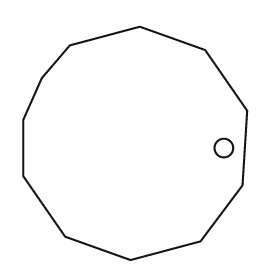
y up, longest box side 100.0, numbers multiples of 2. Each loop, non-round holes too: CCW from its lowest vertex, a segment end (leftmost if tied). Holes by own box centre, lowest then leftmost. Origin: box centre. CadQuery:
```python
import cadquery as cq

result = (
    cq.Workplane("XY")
    .moveTo(-2.0, -50.0)
    .lineTo(28.0, -42.0)
    .lineTo(46.0, -18.0)
    .lineTo(48.0, 14.0)
    .lineTo(30.0, 40.0)
    .lineTo(2.0, 50.0)
    .lineTo(-28.0, 42.0)
    .lineTo(-40.0, 28.0)
    .lineTo(-48.0, 10.0)
    .lineTo(-48.0, -14.0)
    .lineTo(-30.0, -40.0)
    .close()
    .moveTo(38.0, -2.0)
    .circle(4.0)
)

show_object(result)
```